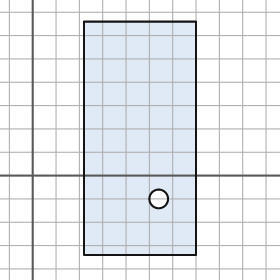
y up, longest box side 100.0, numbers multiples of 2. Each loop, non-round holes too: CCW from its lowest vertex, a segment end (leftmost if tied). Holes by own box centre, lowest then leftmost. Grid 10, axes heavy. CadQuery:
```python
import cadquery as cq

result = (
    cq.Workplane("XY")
    .moveTo(22.0, -34.0)
    .lineTo(70.0, -34.0)
    .lineTo(70.0, 66.0)
    .lineTo(22.0, 66.0)
    .close()
    .moveTo(54.0, -10.0)
    .circle(4.0)
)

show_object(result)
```